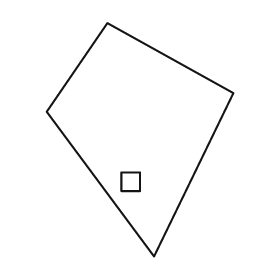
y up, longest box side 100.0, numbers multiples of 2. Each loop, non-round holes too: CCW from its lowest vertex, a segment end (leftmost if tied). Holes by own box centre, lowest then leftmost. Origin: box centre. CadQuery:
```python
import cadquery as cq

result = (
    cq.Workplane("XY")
    .moveTo(6.0, -50.0)
    .lineTo(40.0, 20.0)
    .lineTo(-14.0, 50.0)
    .lineTo(-40.0, 12.0)
    .close()
    .moveTo(-8.0, -22.0)
    .lineTo(0.0, -22.0)
    .lineTo(0.0, -14.0)
    .lineTo(-8.0, -14.0)
    .close()
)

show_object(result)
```